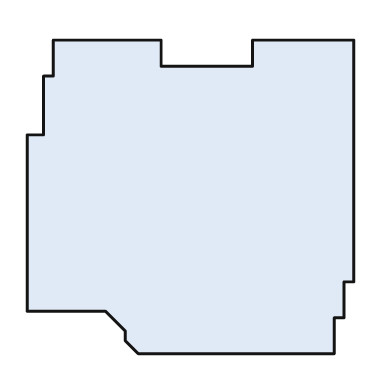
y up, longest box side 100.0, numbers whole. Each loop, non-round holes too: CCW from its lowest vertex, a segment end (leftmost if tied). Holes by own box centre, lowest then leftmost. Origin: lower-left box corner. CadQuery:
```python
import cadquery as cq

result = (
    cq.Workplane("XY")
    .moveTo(34.0, 0.0)
    .lineTo(94.0, 0.0)
    .lineTo(94.0, 11.0)
    .lineTo(97.0, 11.0)
    .lineTo(97.0, 22.0)
    .lineTo(100.0, 22.0)
    .lineTo(100.0, 96.0)
    .lineTo(69.0, 96.0)
    .lineTo(69.0, 88.0)
    .lineTo(41.0, 88.0)
    .lineTo(41.0, 96.0)
    .lineTo(8.0, 96.0)
    .lineTo(8.0, 85.0)
    .lineTo(5.0, 85.0)
    .lineTo(5.0, 67.0)
    .lineTo(0.0, 67.0)
    .lineTo(0.0, 13.0)
    .lineTo(24.0, 13.0)
    .lineTo(30.0, 7.0)
    .lineTo(30.0, 4.0)
    .close()
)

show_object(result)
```